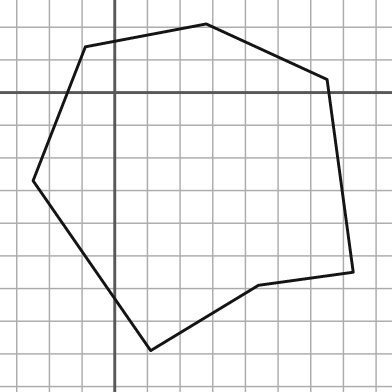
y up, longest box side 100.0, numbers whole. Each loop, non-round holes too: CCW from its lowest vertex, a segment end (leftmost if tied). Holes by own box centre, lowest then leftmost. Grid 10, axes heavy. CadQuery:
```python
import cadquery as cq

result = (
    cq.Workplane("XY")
    .moveTo(11.0, -79.0)
    .lineTo(44.0, -59.0)
    .lineTo(73.0, -55.0)
    .lineTo(65.0, 4.0)
    .lineTo(28.0, 21.0)
    .lineTo(-9.0, 14.0)
    .lineTo(-25.0, -27.0)
    .close()
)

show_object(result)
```